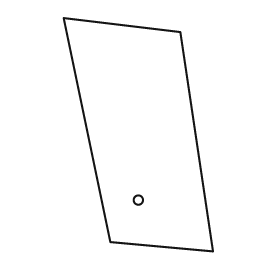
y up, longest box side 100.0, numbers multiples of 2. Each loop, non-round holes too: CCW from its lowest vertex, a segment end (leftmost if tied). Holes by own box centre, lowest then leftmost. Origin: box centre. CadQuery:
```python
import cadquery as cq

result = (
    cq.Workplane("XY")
    .moveTo(32.0, -50.0)
    .lineTo(18.0, 44.0)
    .lineTo(-32.0, 50.0)
    .lineTo(-12.0, -46.0)
    .close()
    .moveTo(0.0, -28.0)
    .circle(2.0)
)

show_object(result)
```